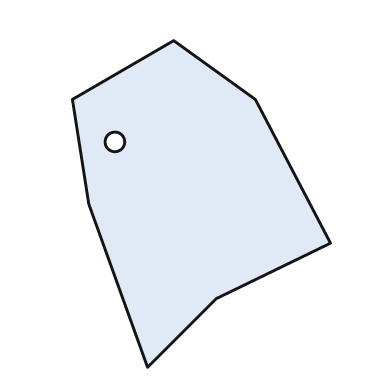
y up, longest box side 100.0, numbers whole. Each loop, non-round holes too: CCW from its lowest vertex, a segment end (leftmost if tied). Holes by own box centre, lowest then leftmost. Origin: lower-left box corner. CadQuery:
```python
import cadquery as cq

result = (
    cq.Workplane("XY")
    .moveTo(23.0, 0.0)
    .lineTo(44.0, 21.0)
    .lineTo(79.0, 38.0)
    .lineTo(56.0, 82.0)
    .lineTo(31.0, 100.0)
    .lineTo(0.0, 82.0)
    .lineTo(5.0, 50.0)
    .close()
    .moveTo(13.0, 69.0)
    .circle(3.0)
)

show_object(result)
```